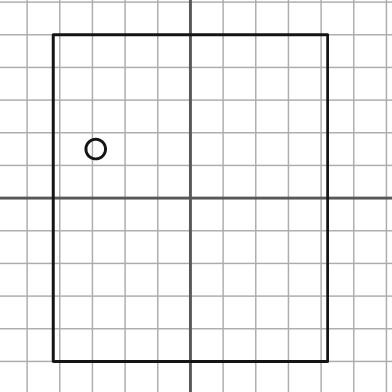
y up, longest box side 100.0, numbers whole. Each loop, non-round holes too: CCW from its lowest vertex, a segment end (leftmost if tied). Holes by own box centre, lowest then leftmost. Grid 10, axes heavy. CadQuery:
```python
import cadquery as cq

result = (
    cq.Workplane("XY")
    .moveTo(-42.0, -50.0)
    .lineTo(42.0, -50.0)
    .lineTo(42.0, 50.0)
    .lineTo(-42.0, 50.0)
    .close()
    .moveTo(-29.0, 15.0)
    .circle(3.0)
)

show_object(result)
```